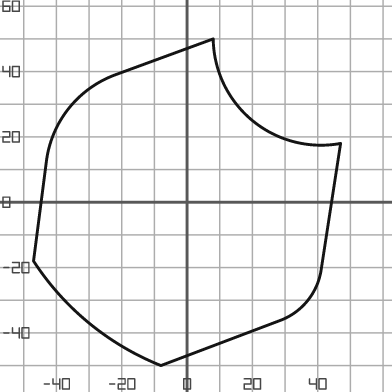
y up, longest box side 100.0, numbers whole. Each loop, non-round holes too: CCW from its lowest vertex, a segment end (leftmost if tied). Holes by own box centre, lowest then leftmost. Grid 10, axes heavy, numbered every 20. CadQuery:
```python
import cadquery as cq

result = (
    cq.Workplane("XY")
    .moveTo(-8.0, -50.0)
    .lineTo(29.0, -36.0)
    .threePointArc((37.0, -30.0), (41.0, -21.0))
    .lineTo(47.0, 18.0)
    .threePointArc((20.0, 25.0), (8.0, 50.0))
    .lineTo(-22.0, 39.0)
    .threePointArc((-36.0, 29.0), (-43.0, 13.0))
    .lineTo(-47.0, -18.0)
    .threePointArc((-30.0, -37.0), (-8.0, -50.0))
    .close()
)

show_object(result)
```